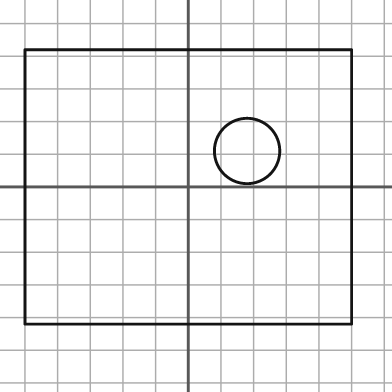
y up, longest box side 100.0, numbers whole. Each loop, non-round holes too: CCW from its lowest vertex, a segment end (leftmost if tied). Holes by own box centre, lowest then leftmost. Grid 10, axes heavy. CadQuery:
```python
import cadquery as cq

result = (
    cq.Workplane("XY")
    .moveTo(-50.0, -42.0)
    .lineTo(50.0, -42.0)
    .lineTo(50.0, 42.0)
    .lineTo(-50.0, 42.0)
    .close()
    .moveTo(18.0, 11.0)
    .circle(10.0)
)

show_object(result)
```